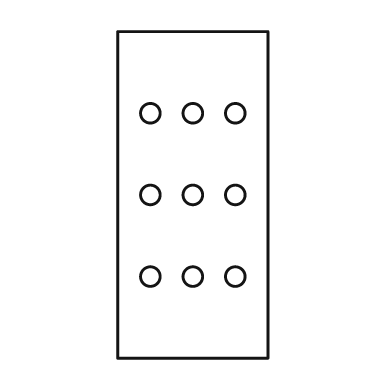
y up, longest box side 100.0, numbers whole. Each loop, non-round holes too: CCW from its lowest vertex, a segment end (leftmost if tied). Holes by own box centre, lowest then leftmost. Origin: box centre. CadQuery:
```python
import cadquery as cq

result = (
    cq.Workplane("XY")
    .moveTo(-23.0, -50.0)
    .lineTo(23.0, -50.0)
    .lineTo(23.0, 50.0)
    .lineTo(-23.0, 50.0)
    .close()
    .moveTo(-13.0, -25.0)
    .circle(3.0)
    .moveTo(0.0, -25.0)
    .circle(3.0)
    .moveTo(13.0, -25.0)
    .circle(3.0)
    .moveTo(-13.0, 0.0)
    .circle(3.0)
    .moveTo(0.0, 0.0)
    .circle(3.0)
    .moveTo(13.0, 0.0)
    .circle(3.0)
    .moveTo(-13.0, 25.0)
    .circle(3.0)
    .moveTo(0.0, 25.0)
    .circle(3.0)
    .moveTo(13.0, 25.0)
    .circle(3.0)
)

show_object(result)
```